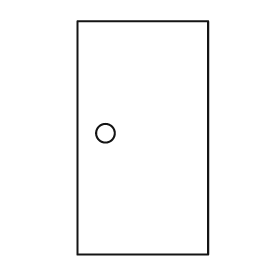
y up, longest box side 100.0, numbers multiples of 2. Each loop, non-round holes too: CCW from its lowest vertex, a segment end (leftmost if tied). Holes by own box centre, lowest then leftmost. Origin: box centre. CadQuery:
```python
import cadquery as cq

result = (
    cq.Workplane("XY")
    .moveTo(-28.0, -50.0)
    .lineTo(28.0, -50.0)
    .lineTo(28.0, 50.0)
    .lineTo(-28.0, 50.0)
    .close()
    .moveTo(-16.0, 2.0)
    .circle(4.0)
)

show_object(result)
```